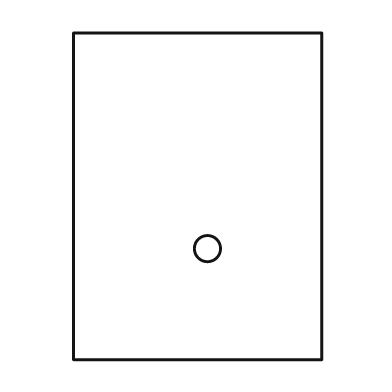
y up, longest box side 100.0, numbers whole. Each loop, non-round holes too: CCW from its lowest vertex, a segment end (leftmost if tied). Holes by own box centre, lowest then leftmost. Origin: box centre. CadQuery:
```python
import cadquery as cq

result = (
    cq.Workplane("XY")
    .moveTo(-38.0, -50.0)
    .lineTo(38.0, -50.0)
    .lineTo(38.0, 50.0)
    .lineTo(-38.0, 50.0)
    .close()
    .moveTo(3.0, -16.0)
    .circle(4.0)
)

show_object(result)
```